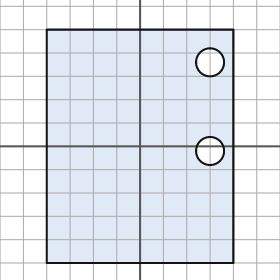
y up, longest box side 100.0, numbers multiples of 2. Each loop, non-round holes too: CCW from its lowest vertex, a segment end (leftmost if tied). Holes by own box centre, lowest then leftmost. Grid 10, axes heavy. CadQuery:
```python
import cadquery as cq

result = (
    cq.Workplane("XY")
    .moveTo(-40.0, -50.0)
    .lineTo(40.0, -50.0)
    .lineTo(40.0, 50.0)
    .lineTo(-40.0, 50.0)
    .close()
    .moveTo(30.0, -2.0)
    .circle(6.0)
    .moveTo(30.0, 36.0)
    .circle(6.0)
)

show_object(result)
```